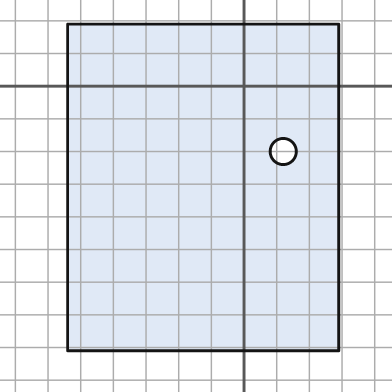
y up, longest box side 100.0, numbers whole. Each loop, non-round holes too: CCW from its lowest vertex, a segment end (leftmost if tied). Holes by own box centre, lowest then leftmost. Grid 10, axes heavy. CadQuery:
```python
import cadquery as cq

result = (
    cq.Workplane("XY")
    .moveTo(-54.0, -81.0)
    .lineTo(29.0, -81.0)
    .lineTo(29.0, 19.0)
    .lineTo(-54.0, 19.0)
    .close()
    .moveTo(12.0, -20.0)
    .circle(4.0)
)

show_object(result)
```